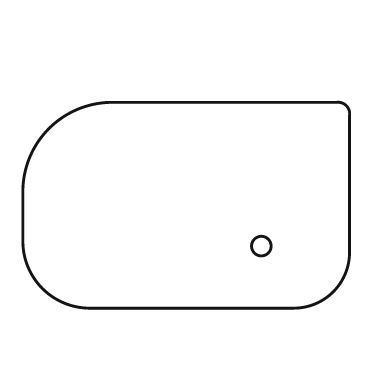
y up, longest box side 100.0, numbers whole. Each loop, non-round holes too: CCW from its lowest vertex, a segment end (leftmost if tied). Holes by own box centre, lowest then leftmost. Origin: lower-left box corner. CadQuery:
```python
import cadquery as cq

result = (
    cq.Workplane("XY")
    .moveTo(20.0, 0.0)
    .lineTo(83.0, 0.0)
    .threePointArc((95.0, 5.0), (100.0, 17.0))
    .lineTo(100.0, 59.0)
    .threePointArc((99.0, 62.0), (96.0, 63.0))
    .lineTo(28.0, 63.0)
    .threePointArc((8.0, 55.0), (0.0, 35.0))
    .lineTo(0.0, 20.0)
    .threePointArc((6.0, 6.0), (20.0, 0.0))
    .close()
    .moveTo(73.0, 19.0)
    .circle(3.0)
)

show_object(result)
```